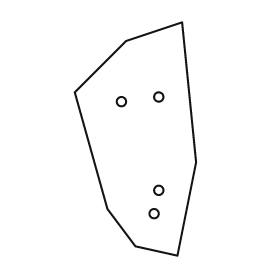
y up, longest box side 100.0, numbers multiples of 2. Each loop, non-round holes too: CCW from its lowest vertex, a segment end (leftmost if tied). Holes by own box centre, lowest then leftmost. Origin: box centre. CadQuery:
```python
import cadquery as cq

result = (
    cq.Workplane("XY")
    .moveTo(18.0, -50.0)
    .lineTo(26.0, -10.0)
    .lineTo(20.0, 50.0)
    .lineTo(-4.0, 42.0)
    .lineTo(-26.0, 20.0)
    .lineTo(-12.0, -30.0)
    .lineTo(0.0, -46.0)
    .close()
    .moveTo(8.0, -32.0)
    .circle(2.0)
    .moveTo(10.0, -22.0)
    .circle(2.0)
    .moveTo(-6.0, 16.0)
    .circle(2.0)
    .moveTo(10.0, 18.0)
    .circle(2.0)
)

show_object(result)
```